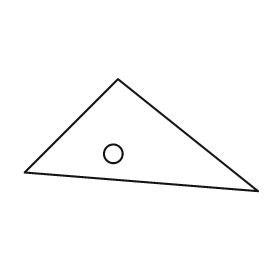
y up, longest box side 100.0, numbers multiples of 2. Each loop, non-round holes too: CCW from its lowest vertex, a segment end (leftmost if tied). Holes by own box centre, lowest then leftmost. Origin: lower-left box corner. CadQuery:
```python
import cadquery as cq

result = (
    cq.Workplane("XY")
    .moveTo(100.0, 0.0)
    .lineTo(40.0, 48.0)
    .lineTo(0.0, 8.0)
    .close()
    .moveTo(38.0, 16.0)
    .circle(4.0)
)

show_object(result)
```